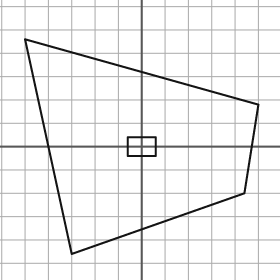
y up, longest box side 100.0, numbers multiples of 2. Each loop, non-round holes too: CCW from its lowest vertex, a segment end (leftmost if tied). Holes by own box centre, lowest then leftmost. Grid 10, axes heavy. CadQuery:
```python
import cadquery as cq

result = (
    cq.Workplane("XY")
    .moveTo(-30.0, -46.0)
    .lineTo(44.0, -20.0)
    .lineTo(50.0, 18.0)
    .lineTo(-50.0, 46.0)
    .close()
    .moveTo(-6.0, -4.0)
    .lineTo(6.0, -4.0)
    .lineTo(6.0, 4.0)
    .lineTo(-6.0, 4.0)
    .close()
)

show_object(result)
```